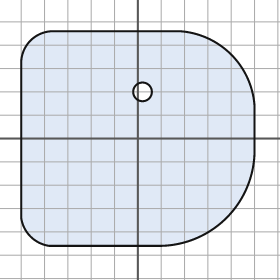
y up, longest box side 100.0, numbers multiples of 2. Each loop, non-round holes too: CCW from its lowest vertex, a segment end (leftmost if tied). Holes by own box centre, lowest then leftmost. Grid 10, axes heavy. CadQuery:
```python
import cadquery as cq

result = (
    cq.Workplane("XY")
    .moveTo(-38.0, -46.0)
    .lineTo(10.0, -46.0)
    .threePointArc((38.0, -34.0), (50.0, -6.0))
    .lineTo(50.0, 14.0)
    .threePointArc((40.0, 36.0), (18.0, 46.0))
    .lineTo(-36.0, 46.0)
    .threePointArc((-46.0, 42.0), (-50.0, 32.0))
    .lineTo(-50.0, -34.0)
    .threePointArc((-46.0, -42.0), (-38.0, -46.0))
    .close()
    .moveTo(2.0, 20.0)
    .circle(4.0)
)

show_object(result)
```